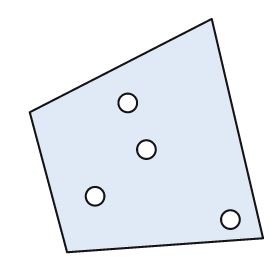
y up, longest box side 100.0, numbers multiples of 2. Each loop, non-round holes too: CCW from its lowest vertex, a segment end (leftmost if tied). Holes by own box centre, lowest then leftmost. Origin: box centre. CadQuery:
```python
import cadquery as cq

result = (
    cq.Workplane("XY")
    .moveTo(-34.0, -50.0)
    .lineTo(50.0, -44.0)
    .lineTo(28.0, 50.0)
    .lineTo(-50.0, 10.0)
    .close()
    .moveTo(36.0, -36.0)
    .circle(4.0)
    .moveTo(-22.0, -26.0)
    .circle(4.0)
    .moveTo(0.0, -6.0)
    .circle(4.0)
    .moveTo(-8.0, 14.0)
    .circle(4.0)
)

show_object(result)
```